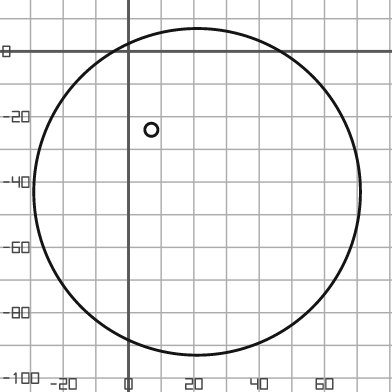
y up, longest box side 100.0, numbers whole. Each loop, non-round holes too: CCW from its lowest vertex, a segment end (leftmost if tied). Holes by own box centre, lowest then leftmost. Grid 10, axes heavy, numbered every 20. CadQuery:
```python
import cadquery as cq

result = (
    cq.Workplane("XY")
    .moveTo(21.0, -43.0)
    .circle(50.0)
    .moveTo(7.0, -24.0)
    .circle(2.0)
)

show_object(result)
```